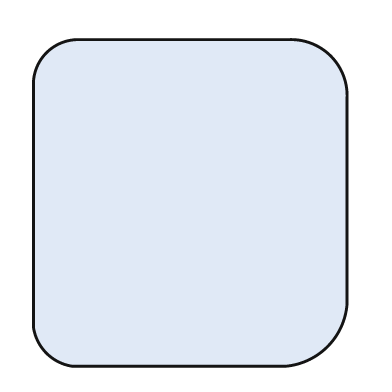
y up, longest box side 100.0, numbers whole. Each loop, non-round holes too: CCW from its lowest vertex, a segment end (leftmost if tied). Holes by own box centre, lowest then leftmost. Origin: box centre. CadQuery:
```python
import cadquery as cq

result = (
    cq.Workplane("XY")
    .moveTo(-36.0, -50.0)
    .lineTo(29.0, -50.0)
    .threePointArc((42.0, -44.0), (48.0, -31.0))
    .lineTo(48.0, 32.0)
    .threePointArc((43.0, 45.0), (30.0, 50.0))
    .lineTo(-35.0, 50.0)
    .threePointArc((-44.0, 46.0), (-48.0, 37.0))
    .lineTo(-48.0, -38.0)
    .threePointArc((-44.0, -46.0), (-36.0, -50.0))
    .close()
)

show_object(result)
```